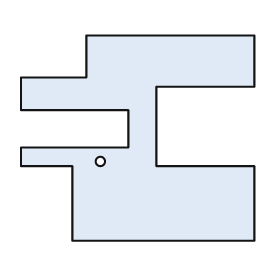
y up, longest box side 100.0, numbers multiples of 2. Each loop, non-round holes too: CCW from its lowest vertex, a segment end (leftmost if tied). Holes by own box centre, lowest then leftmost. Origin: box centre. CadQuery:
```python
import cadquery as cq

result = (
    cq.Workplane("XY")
    .moveTo(-28.0, -44.0)
    .lineTo(50.0, -44.0)
    .lineTo(50.0, -12.0)
    .lineTo(8.0, -12.0)
    .lineTo(8.0, 22.0)
    .lineTo(50.0, 22.0)
    .lineTo(50.0, 44.0)
    .lineTo(-22.0, 44.0)
    .lineTo(-22.0, 26.0)
    .lineTo(-50.0, 26.0)
    .lineTo(-50.0, 12.0)
    .lineTo(-4.0, 12.0)
    .lineTo(-4.0, -4.0)
    .lineTo(-50.0, -4.0)
    .lineTo(-50.0, -12.0)
    .lineTo(-28.0, -12.0)
    .close()
    .moveTo(-16.0, -10.0)
    .circle(2.0)
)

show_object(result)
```